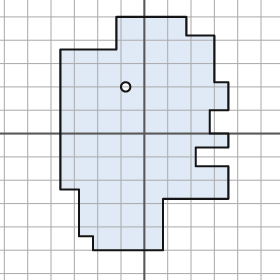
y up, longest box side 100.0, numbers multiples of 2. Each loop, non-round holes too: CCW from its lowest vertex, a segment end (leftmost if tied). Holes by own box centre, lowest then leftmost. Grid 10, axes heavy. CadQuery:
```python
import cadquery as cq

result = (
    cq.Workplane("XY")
    .moveTo(-22.0, -50.0)
    .lineTo(8.0, -50.0)
    .lineTo(8.0, -28.0)
    .lineTo(36.0, -28.0)
    .lineTo(36.0, -14.0)
    .lineTo(22.0, -14.0)
    .lineTo(22.0, -6.0)
    .lineTo(36.0, -6.0)
    .lineTo(36.0, 0.0)
    .lineTo(28.0, 0.0)
    .lineTo(28.0, 10.0)
    .lineTo(36.0, 10.0)
    .lineTo(36.0, 22.0)
    .lineTo(30.0, 22.0)
    .lineTo(30.0, 42.0)
    .lineTo(18.0, 42.0)
    .lineTo(18.0, 50.0)
    .lineTo(-12.0, 50.0)
    .lineTo(-12.0, 36.0)
    .lineTo(-36.0, 36.0)
    .lineTo(-36.0, -24.0)
    .lineTo(-28.0, -24.0)
    .lineTo(-28.0, -44.0)
    .lineTo(-22.0, -44.0)
    .close()
    .moveTo(-8.0, 20.0)
    .circle(2.0)
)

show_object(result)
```